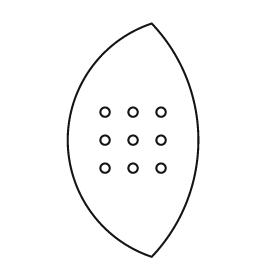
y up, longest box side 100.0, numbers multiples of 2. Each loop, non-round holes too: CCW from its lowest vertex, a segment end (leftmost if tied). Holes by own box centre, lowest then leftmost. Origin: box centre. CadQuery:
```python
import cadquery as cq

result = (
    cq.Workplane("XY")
    .moveTo(8.0, -50.0)
    .threePointArc((28.0, 0.0), (8.0, 50.0))
    .threePointArc((-28.0, 0.0), (8.0, -50.0))
    .close()
    .moveTo(-12.0, -12.0)
    .circle(2.0)
    .moveTo(0.0, -12.0)
    .circle(2.0)
    .moveTo(12.0, -12.0)
    .circle(2.0)
    .moveTo(-12.0, 0.0)
    .circle(2.0)
    .moveTo(0.0, 0.0)
    .circle(2.0)
    .moveTo(12.0, 0.0)
    .circle(2.0)
    .moveTo(-12.0, 12.0)
    .circle(2.0)
    .moveTo(0.0, 12.0)
    .circle(2.0)
    .moveTo(12.0, 12.0)
    .circle(2.0)
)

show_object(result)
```